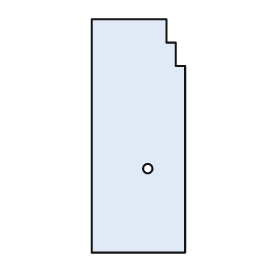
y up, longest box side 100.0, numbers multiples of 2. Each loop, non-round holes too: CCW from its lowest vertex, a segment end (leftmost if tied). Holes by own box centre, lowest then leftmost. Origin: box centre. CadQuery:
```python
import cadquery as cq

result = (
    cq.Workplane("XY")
    .moveTo(-20.0, -50.0)
    .lineTo(20.0, -50.0)
    .lineTo(20.0, 30.0)
    .lineTo(16.0, 30.0)
    .lineTo(16.0, 40.0)
    .lineTo(12.0, 40.0)
    .lineTo(12.0, 50.0)
    .lineTo(-20.0, 50.0)
    .close()
    .moveTo(4.0, -14.0)
    .circle(2.0)
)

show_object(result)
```